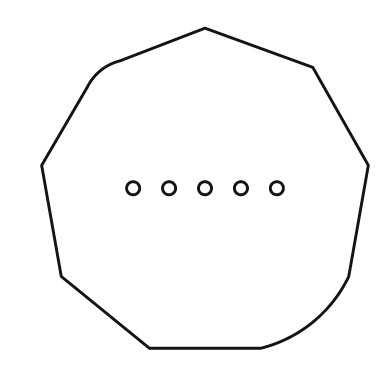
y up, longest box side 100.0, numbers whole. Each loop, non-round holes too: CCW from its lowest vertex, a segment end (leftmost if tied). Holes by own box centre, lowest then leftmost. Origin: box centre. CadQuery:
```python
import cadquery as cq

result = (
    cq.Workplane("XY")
    .moveTo(-17.0, -49.0)
    .lineTo(17.0, -49.0)
    .threePointArc((33.0, -41.0), (44.0, -27.0))
    .lineTo(50.0, 7.0)
    .lineTo(33.0, 37.0)
    .lineTo(0.0, 49.0)
    .lineTo(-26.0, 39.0)
    .threePointArc((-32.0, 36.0), (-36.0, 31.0))
    .lineTo(-50.0, 7.0)
    .lineTo(-44.0, -27.0)
    .close()
    .moveTo(-22.0, 0.0)
    .circle(2.0)
    .moveTo(-11.0, 0.0)
    .circle(2.0)
    .moveTo(0.0, 0.0)
    .circle(2.0)
    .moveTo(11.0, 0.0)
    .circle(2.0)
    .moveTo(22.0, 0.0)
    .circle(2.0)
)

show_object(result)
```